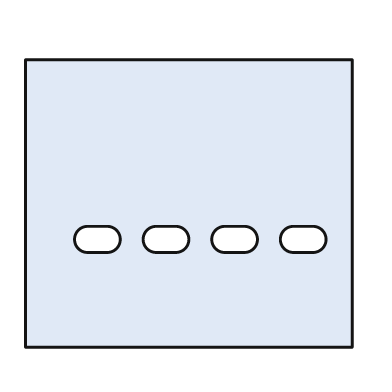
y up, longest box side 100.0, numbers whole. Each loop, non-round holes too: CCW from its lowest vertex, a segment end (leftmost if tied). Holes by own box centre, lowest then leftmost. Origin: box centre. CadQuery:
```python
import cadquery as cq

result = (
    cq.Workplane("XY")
    .moveTo(-50.0, -44.0)
    .lineTo(50.0, -44.0)
    .lineTo(50.0, 44.0)
    .lineTo(-50.0, 44.0)
    .close()
    .moveTo(-31.0, -15.0)
    .lineTo(-25.0, -15.0)
    .threePointArc((-21.0, -11.0), (-25.0, -7.0))
    .lineTo(-31.0, -7.0)
    .threePointArc((-35.0, -11.0), (-31.0, -15.0))
    .close()
    .moveTo(-10.0, -15.0)
    .lineTo(-4.0, -15.0)
    .threePointArc((0.0, -11.0), (-4.0, -7.0))
    .lineTo(-10.0, -7.0)
    .threePointArc((-14.0, -11.0), (-10.0, -15.0))
    .close()
    .moveTo(11.0, -15.0)
    .lineTo(17.0, -15.0)
    .threePointArc((21.0, -11.0), (17.0, -7.0))
    .lineTo(11.0, -7.0)
    .threePointArc((7.0, -11.0), (11.0, -15.0))
    .close()
    .moveTo(32.0, -15.0)
    .lineTo(38.0, -15.0)
    .threePointArc((42.0, -11.0), (38.0, -7.0))
    .lineTo(32.0, -7.0)
    .threePointArc((28.0, -11.0), (32.0, -15.0))
    .close()
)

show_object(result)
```